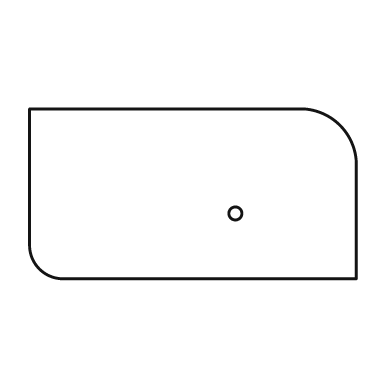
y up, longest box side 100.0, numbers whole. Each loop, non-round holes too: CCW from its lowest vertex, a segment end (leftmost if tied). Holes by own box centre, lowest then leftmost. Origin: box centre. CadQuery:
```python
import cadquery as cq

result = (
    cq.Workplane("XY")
    .moveTo(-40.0, -26.0)
    .lineTo(50.0, -26.0)
    .lineTo(50.0, 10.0)
    .threePointArc((45.0, 21.0), (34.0, 26.0))
    .lineTo(-50.0, 26.0)
    .lineTo(-50.0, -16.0)
    .threePointArc((-47.0, -23.0), (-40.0, -26.0))
    .close()
    .moveTo(13.0, -6.0)
    .circle(2.0)
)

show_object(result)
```